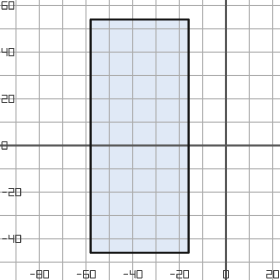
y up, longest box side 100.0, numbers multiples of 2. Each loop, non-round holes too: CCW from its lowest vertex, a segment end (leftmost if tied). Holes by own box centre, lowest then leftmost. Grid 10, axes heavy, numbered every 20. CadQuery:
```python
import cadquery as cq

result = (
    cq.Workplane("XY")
    .moveTo(-58.0, -46.0)
    .lineTo(-16.0, -46.0)
    .lineTo(-16.0, 54.0)
    .lineTo(-58.0, 54.0)
    .close()
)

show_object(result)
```